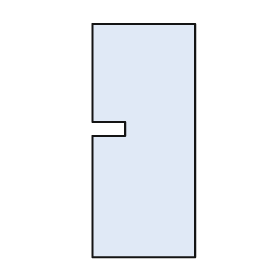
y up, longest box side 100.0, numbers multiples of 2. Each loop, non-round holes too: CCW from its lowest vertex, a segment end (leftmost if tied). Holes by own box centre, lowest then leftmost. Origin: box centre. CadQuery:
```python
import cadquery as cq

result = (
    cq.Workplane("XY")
    .moveTo(-22.0, -50.0)
    .lineTo(22.0, -50.0)
    .lineTo(22.0, 50.0)
    .lineTo(-22.0, 50.0)
    .lineTo(-22.0, 8.0)
    .lineTo(-8.0, 8.0)
    .lineTo(-8.0, 2.0)
    .lineTo(-22.0, 2.0)
    .close()
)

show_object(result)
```